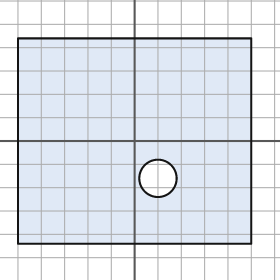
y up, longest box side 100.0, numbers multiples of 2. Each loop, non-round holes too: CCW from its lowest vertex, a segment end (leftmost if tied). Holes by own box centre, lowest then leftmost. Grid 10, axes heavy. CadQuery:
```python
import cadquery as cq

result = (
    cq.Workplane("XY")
    .moveTo(-50.0, -44.0)
    .lineTo(50.0, -44.0)
    .lineTo(50.0, 44.0)
    .lineTo(-50.0, 44.0)
    .close()
    .moveTo(10.0, -16.0)
    .circle(8.0)
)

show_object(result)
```